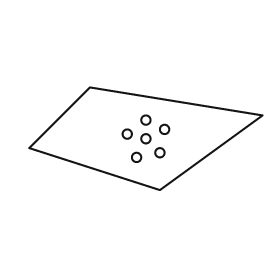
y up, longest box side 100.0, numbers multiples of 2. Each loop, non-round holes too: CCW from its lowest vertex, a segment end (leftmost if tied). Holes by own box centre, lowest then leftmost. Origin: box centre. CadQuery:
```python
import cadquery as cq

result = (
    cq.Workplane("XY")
    .moveTo(6.0, -22.0)
    .lineTo(50.0, 10.0)
    .lineTo(-24.0, 22.0)
    .lineTo(-50.0, -4.0)
    .close()
    .moveTo(-4.0, -8.0)
    .circle(2.0)
    .moveTo(6.0, -6.0)
    .circle(2.0)
    .moveTo(0.0, 0.0)
    .circle(2.0)
    .moveTo(-8.0, 2.0)
    .circle(2.0)
    .moveTo(8.0, 4.0)
    .circle(2.0)
    .moveTo(0.0, 8.0)
    .circle(2.0)
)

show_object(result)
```